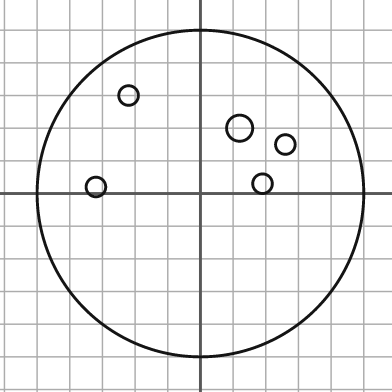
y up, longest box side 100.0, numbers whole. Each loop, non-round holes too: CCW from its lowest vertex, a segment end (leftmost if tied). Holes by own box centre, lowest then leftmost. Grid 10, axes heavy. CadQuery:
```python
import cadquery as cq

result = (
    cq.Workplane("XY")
    .moveTo(0.0, 0.0)
    .circle(50.0)
    .moveTo(-32.0, 2.0)
    .circle(3.0)
    .moveTo(19.0, 3.0)
    .circle(3.0)
    .moveTo(26.0, 15.0)
    .circle(3.0)
    .moveTo(12.0, 20.0)
    .circle(4.0)
    .moveTo(-22.0, 30.0)
    .circle(3.0)
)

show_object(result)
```